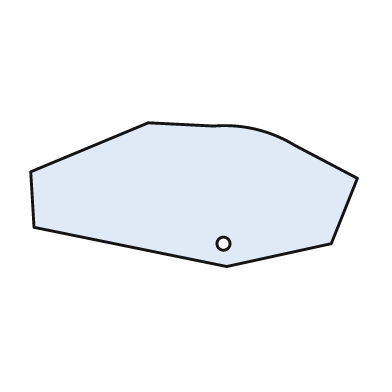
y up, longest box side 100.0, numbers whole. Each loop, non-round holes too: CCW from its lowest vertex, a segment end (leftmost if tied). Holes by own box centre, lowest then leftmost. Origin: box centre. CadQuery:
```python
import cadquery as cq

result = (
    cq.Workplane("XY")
    .moveTo(10.0, -22.0)
    .lineTo(42.0, -15.0)
    .lineTo(50.0, 5.0)
    .lineTo(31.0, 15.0)
    .threePointArc((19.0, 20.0), (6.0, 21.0))
    .lineTo(-14.0, 22.0)
    .lineTo(-50.0, 7.0)
    .lineTo(-49.0, -10.0)
    .close()
    .moveTo(9.0, -15.0)
    .circle(2.0)
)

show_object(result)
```